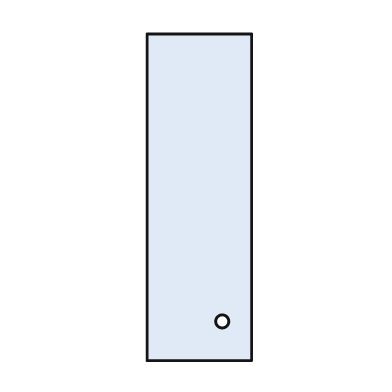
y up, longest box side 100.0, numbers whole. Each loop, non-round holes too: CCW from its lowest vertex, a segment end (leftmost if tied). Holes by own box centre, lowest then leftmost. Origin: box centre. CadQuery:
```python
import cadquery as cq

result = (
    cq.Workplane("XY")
    .moveTo(-16.0, -50.0)
    .lineTo(16.0, -50.0)
    .lineTo(16.0, 50.0)
    .lineTo(-16.0, 50.0)
    .close()
    .moveTo(7.0, -38.0)
    .circle(2.0)
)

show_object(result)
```